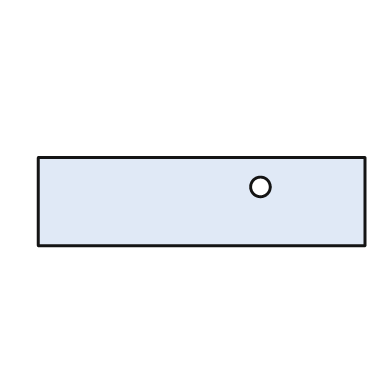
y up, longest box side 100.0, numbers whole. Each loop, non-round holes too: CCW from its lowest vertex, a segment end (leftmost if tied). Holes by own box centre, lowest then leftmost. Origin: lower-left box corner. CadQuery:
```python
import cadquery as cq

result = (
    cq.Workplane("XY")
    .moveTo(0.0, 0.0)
    .lineTo(100.0, 0.0)
    .lineTo(100.0, 27.0)
    .lineTo(0.0, 27.0)
    .close()
    .moveTo(68.0, 18.0)
    .circle(3.0)
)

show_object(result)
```